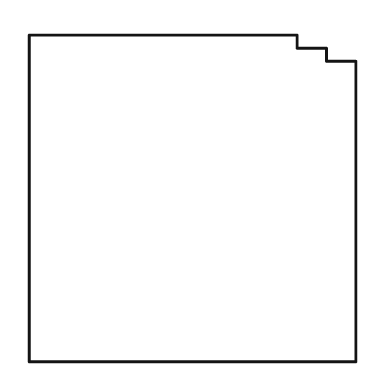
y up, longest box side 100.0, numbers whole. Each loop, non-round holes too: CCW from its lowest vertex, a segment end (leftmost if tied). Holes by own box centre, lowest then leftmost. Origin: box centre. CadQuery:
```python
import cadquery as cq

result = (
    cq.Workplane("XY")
    .moveTo(-50.0, -50.0)
    .lineTo(50.0, -50.0)
    .lineTo(50.0, 42.0)
    .lineTo(41.0, 42.0)
    .lineTo(41.0, 46.0)
    .lineTo(32.0, 46.0)
    .lineTo(32.0, 50.0)
    .lineTo(-50.0, 50.0)
    .close()
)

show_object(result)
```